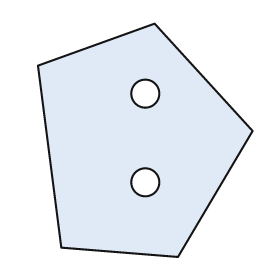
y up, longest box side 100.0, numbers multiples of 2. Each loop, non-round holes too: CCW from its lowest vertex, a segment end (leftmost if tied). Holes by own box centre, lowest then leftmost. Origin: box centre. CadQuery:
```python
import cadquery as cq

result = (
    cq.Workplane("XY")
    .moveTo(14.0, -50.0)
    .lineTo(46.0, 4.0)
    .lineTo(4.0, 50.0)
    .lineTo(-46.0, 32.0)
    .lineTo(-36.0, -46.0)
    .close()
    .moveTo(0.0, -18.0)
    .circle(6.0)
    .moveTo(0.0, 20.0)
    .circle(6.0)
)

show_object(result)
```